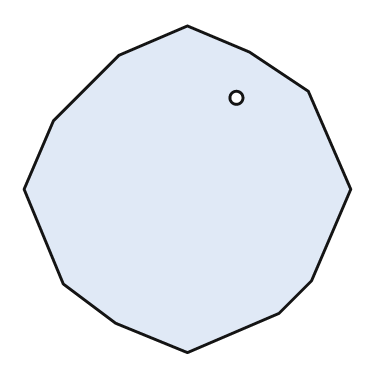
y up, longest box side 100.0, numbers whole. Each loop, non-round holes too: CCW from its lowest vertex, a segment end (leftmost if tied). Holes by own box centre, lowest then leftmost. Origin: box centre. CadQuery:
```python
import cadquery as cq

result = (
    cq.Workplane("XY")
    .moveTo(0.0, -50.0)
    .lineTo(28.0, -38.0)
    .lineTo(38.0, -28.0)
    .lineTo(50.0, 0.0)
    .lineTo(37.0, 30.0)
    .lineTo(19.0, 42.0)
    .lineTo(0.0, 50.0)
    .lineTo(-21.0, 41.0)
    .lineTo(-41.0, 21.0)
    .lineTo(-50.0, 0.0)
    .lineTo(-38.0, -29.0)
    .lineTo(-22.0, -41.0)
    .close()
    .moveTo(15.0, 28.0)
    .circle(2.0)
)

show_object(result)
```